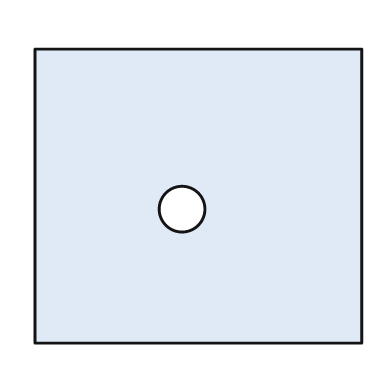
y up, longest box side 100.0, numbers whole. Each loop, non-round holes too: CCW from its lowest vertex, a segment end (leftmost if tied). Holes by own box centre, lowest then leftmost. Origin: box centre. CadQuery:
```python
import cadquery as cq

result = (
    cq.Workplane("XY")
    .moveTo(-50.0, -45.0)
    .lineTo(50.0, -45.0)
    .lineTo(50.0, 45.0)
    .lineTo(-50.0, 45.0)
    .close()
    .moveTo(-5.0, -4.0)
    .circle(7.0)
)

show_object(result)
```